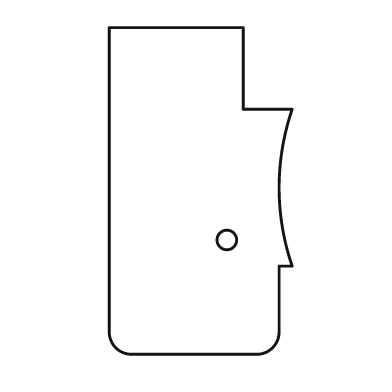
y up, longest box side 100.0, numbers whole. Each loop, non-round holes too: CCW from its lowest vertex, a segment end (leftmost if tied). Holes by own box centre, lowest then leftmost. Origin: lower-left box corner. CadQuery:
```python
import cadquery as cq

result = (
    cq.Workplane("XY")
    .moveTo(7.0, 0.0)
    .lineTo(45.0, 0.0)
    .threePointArc((50.0, 2.0), (52.0, 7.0))
    .lineTo(52.0, 27.0)
    .lineTo(56.0, 27.0)
    .threePointArc((52.0, 51.0), (56.0, 75.0))
    .lineTo(41.0, 75.0)
    .lineTo(41.0, 100.0)
    .lineTo(0.0, 100.0)
    .lineTo(0.0, 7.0)
    .threePointArc((2.0, 2.0), (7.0, 0.0))
    .close()
    .moveTo(36.0, 35.0)
    .circle(3.0)
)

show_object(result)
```